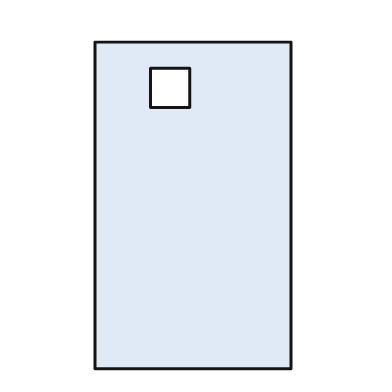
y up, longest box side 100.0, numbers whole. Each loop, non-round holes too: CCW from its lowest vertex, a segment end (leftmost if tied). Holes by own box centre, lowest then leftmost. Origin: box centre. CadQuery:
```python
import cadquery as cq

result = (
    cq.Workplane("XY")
    .moveTo(-30.0, -50.0)
    .lineTo(30.0, -50.0)
    .lineTo(30.0, 50.0)
    .lineTo(-30.0, 50.0)
    .close()
    .moveTo(-13.0, 30.0)
    .lineTo(-1.0, 30.0)
    .lineTo(-1.0, 42.0)
    .lineTo(-13.0, 42.0)
    .close()
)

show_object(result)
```